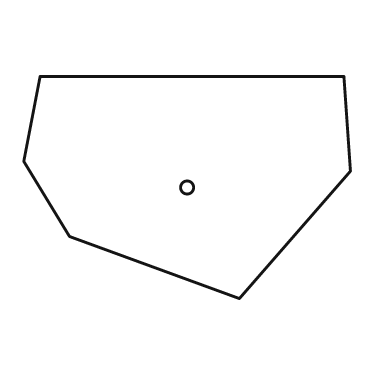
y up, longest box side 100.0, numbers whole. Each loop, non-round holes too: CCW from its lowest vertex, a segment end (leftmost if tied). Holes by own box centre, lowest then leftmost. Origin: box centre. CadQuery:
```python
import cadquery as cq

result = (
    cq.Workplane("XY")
    .moveTo(16.0, -34.0)
    .lineTo(50.0, 5.0)
    .lineTo(48.0, 34.0)
    .lineTo(-45.0, 34.0)
    .lineTo(-50.0, 8.0)
    .lineTo(-36.0, -15.0)
    .close()
    .moveTo(0.0, 0.0)
    .circle(2.0)
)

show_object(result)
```